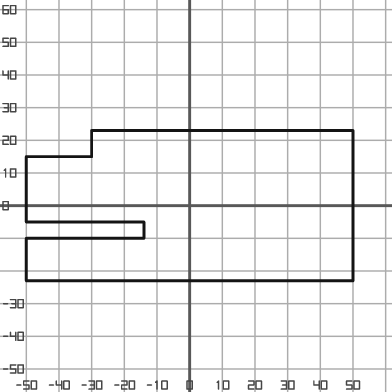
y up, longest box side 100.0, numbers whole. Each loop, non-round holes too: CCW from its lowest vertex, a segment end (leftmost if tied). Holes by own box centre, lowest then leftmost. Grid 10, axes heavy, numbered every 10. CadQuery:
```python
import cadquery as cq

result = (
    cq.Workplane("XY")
    .moveTo(-50.0, -23.0)
    .lineTo(50.0, -23.0)
    .lineTo(50.0, 23.0)
    .lineTo(-30.0, 23.0)
    .lineTo(-30.0, 15.0)
    .lineTo(-50.0, 15.0)
    .lineTo(-50.0, -5.0)
    .lineTo(-14.0, -5.0)
    .lineTo(-14.0, -10.0)
    .lineTo(-50.0, -10.0)
    .close()
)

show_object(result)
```